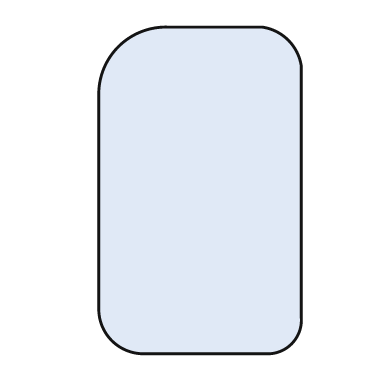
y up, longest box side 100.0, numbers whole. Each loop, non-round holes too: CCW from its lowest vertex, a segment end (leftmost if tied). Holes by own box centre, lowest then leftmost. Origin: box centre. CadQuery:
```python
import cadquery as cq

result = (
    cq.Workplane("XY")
    .moveTo(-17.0, -50.0)
    .lineTo(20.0, -50.0)
    .threePointArc((28.0, -47.0), (31.0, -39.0))
    .lineTo(31.0, 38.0)
    .threePointArc((27.0, 46.0), (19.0, 50.0))
    .lineTo(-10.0, 50.0)
    .threePointArc((-25.0, 44.0), (-31.0, 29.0))
    .lineTo(-31.0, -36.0)
    .threePointArc((-27.0, -46.0), (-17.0, -50.0))
    .close()
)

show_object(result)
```